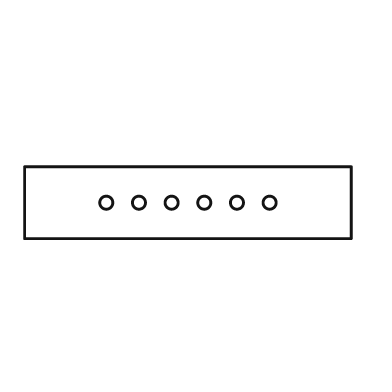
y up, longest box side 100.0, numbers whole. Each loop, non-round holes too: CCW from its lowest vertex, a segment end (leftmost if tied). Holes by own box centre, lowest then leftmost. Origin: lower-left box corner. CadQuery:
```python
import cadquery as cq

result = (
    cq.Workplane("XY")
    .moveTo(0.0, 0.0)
    .lineTo(100.0, 0.0)
    .lineTo(100.0, 22.0)
    .lineTo(0.0, 22.0)
    .close()
    .moveTo(25.0, 11.0)
    .circle(2.0)
    .moveTo(35.0, 11.0)
    .circle(2.0)
    .moveTo(45.0, 11.0)
    .circle(2.0)
    .moveTo(55.0, 11.0)
    .circle(2.0)
    .moveTo(65.0, 11.0)
    .circle(2.0)
    .moveTo(75.0, 11.0)
    .circle(2.0)
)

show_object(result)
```